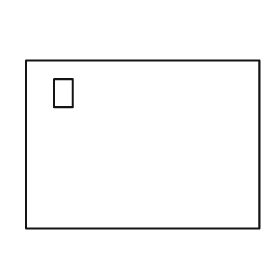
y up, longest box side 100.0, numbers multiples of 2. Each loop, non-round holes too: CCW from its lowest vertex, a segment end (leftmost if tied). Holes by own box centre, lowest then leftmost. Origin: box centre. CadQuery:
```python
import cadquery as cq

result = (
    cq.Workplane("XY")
    .moveTo(-50.0, -36.0)
    .lineTo(50.0, -36.0)
    .lineTo(50.0, 36.0)
    .lineTo(-50.0, 36.0)
    .close()
    .moveTo(-38.0, 16.0)
    .lineTo(-30.0, 16.0)
    .lineTo(-30.0, 28.0)
    .lineTo(-38.0, 28.0)
    .close()
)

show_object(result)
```